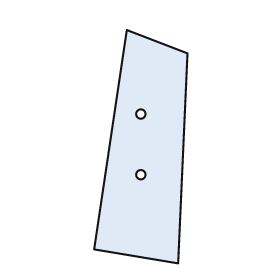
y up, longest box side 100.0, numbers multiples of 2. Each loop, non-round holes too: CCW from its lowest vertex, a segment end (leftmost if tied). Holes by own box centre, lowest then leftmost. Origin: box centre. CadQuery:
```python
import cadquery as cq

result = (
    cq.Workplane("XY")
    .moveTo(16.0, -50.0)
    .lineTo(20.0, 40.0)
    .lineTo(-6.0, 50.0)
    .lineTo(-20.0, -44.0)
    .close()
    .moveTo(0.0, -12.0)
    .circle(2.0)
    .moveTo(0.0, 14.0)
    .circle(2.0)
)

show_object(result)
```